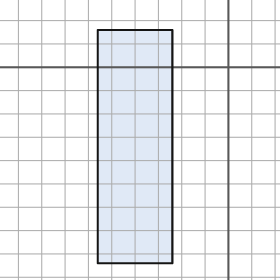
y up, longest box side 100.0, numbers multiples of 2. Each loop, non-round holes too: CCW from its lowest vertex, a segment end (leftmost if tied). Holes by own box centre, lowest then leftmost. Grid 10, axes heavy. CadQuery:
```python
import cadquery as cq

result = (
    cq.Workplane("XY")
    .moveTo(-56.0, -84.0)
    .lineTo(-24.0, -84.0)
    .lineTo(-24.0, 16.0)
    .lineTo(-56.0, 16.0)
    .close()
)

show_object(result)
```